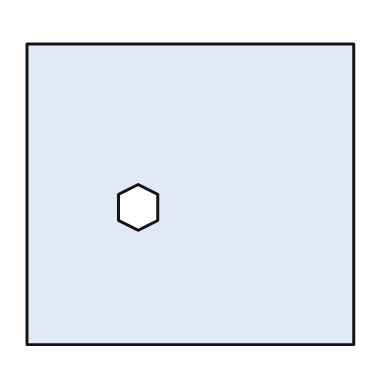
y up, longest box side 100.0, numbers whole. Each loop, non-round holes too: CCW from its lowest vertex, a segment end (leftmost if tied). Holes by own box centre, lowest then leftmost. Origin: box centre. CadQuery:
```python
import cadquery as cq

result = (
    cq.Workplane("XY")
    .moveTo(-50.0, -46.0)
    .lineTo(50.0, -46.0)
    .lineTo(50.0, 46.0)
    .lineTo(-50.0, 46.0)
    .close()
    .moveTo(-16.0, -11.0)
    .lineTo(-10.0, -8.0)
    .lineTo(-10.0, 0.0)
    .lineTo(-16.0, 3.0)
    .lineTo(-22.0, 0.0)
    .lineTo(-22.0, -8.0)
    .close()
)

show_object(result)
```